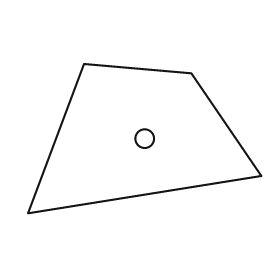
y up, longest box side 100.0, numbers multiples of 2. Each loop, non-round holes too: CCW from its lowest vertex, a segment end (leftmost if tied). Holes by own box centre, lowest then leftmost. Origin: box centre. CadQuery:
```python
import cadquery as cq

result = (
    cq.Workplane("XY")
    .moveTo(-50.0, -32.0)
    .lineTo(50.0, -16.0)
    .lineTo(20.0, 28.0)
    .lineTo(-26.0, 32.0)
    .close()
    .moveTo(0.0, 0.0)
    .circle(4.0)
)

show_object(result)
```